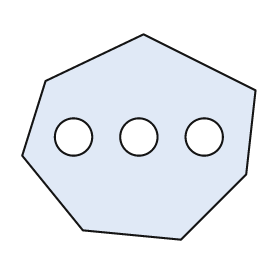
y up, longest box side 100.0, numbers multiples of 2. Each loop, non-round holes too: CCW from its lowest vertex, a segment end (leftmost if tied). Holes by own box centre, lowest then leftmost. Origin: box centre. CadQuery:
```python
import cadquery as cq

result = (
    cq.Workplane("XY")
    .moveTo(18.0, -44.0)
    .lineTo(46.0, -16.0)
    .lineTo(50.0, 20.0)
    .lineTo(2.0, 44.0)
    .lineTo(-40.0, 24.0)
    .lineTo(-50.0, -8.0)
    .lineTo(-24.0, -40.0)
    .close()
    .moveTo(-28.0, 0.0)
    .circle(8.0)
    .moveTo(0.0, 0.0)
    .circle(8.0)
    .moveTo(28.0, 0.0)
    .circle(8.0)
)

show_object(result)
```